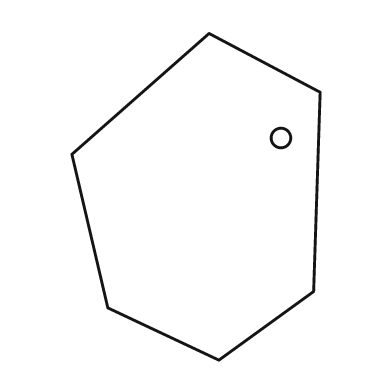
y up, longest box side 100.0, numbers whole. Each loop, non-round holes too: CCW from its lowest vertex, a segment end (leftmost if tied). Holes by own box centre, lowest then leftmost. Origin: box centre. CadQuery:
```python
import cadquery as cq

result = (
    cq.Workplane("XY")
    .moveTo(7.0, -50.0)
    .lineTo(36.0, -29.0)
    .lineTo(38.0, 32.0)
    .lineTo(4.0, 50.0)
    .lineTo(-38.0, 13.0)
    .lineTo(-27.0, -34.0)
    .close()
    .moveTo(26.0, 18.0)
    .circle(3.0)
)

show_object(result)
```